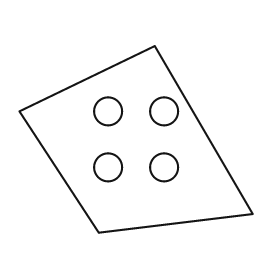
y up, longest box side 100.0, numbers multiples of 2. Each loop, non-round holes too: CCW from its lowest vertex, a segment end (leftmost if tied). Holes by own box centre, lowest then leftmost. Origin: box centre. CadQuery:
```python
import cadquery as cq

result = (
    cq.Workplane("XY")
    .moveTo(-16.0, -40.0)
    .lineTo(50.0, -32.0)
    .lineTo(8.0, 40.0)
    .lineTo(-50.0, 12.0)
    .close()
    .moveTo(-12.0, -12.0)
    .circle(6.0)
    .moveTo(12.0, -12.0)
    .circle(6.0)
    .moveTo(-12.0, 12.0)
    .circle(6.0)
    .moveTo(12.0, 12.0)
    .circle(6.0)
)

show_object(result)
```